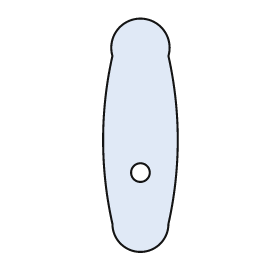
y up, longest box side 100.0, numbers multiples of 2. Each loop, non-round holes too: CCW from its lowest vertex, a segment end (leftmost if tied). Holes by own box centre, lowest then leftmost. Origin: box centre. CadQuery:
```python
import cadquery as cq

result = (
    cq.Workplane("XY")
    .moveTo(-12.0, -38.0)
    .threePointArc((0.0, -50.0), (12.0, -38.0))
    .threePointArc((16.0, -2.0), (12.0, 34.0))
    .threePointArc((0.0, 50.0), (-12.0, 34.0))
    .threePointArc((-16.0, -2.0), (-12.0, -38.0))
    .close()
    .moveTo(0.0, -16.0)
    .circle(4.0)
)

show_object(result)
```